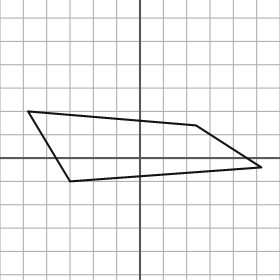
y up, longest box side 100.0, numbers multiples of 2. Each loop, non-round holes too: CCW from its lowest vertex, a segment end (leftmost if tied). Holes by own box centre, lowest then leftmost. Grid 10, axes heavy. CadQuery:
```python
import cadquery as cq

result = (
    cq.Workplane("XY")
    .moveTo(-30.0, -10.0)
    .lineTo(52.0, -4.0)
    .lineTo(24.0, 14.0)
    .lineTo(-48.0, 20.0)
    .close()
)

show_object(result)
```